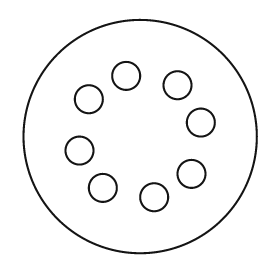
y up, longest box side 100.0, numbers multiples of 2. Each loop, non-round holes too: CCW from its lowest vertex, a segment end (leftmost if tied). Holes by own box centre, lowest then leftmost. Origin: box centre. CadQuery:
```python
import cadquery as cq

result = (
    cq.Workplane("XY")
    .moveTo(0.0, 0.0)
    .circle(50.0)
    .moveTo(6.0, -26.0)
    .circle(6.0)
    .moveTo(-16.0, -22.0)
    .circle(6.0)
    .moveTo(22.0, -16.0)
    .circle(6.0)
    .moveTo(-26.0, -6.0)
    .circle(6.0)
    .moveTo(26.0, 6.0)
    .circle(6.0)
    .moveTo(-22.0, 16.0)
    .circle(6.0)
    .moveTo(16.0, 22.0)
    .circle(6.0)
    .moveTo(-6.0, 26.0)
    .circle(6.0)
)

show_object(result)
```